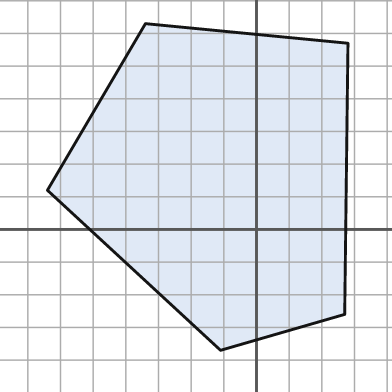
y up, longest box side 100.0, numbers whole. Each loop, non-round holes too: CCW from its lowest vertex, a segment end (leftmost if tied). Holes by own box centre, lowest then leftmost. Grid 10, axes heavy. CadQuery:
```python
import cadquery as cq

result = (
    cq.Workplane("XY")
    .moveTo(-11.0, -37.0)
    .lineTo(27.0, -26.0)
    .lineTo(28.0, 57.0)
    .lineTo(-34.0, 63.0)
    .lineTo(-64.0, 12.0)
    .close()
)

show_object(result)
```